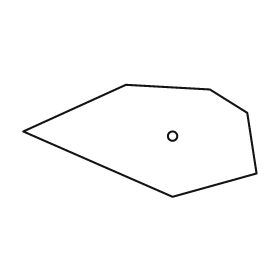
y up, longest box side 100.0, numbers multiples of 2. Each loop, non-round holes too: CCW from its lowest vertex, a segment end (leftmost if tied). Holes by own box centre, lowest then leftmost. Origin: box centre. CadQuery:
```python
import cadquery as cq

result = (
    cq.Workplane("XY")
    .moveTo(14.0, -24.0)
    .lineTo(50.0, -14.0)
    .lineTo(46.0, 12.0)
    .lineTo(30.0, 22.0)
    .lineTo(-6.0, 24.0)
    .lineTo(-50.0, 4.0)
    .close()
    .moveTo(14.0, 2.0)
    .circle(2.0)
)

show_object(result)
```